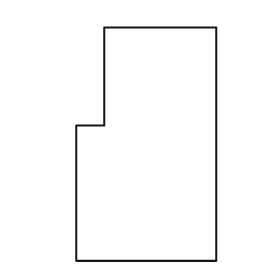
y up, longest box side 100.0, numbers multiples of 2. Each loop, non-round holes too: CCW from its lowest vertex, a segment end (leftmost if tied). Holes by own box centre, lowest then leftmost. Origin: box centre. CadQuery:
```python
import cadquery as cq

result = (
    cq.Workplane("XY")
    .moveTo(-30.0, -50.0)
    .lineTo(30.0, -50.0)
    .lineTo(30.0, 50.0)
    .lineTo(-18.0, 50.0)
    .lineTo(-18.0, 8.0)
    .lineTo(-30.0, 8.0)
    .close()
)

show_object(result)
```